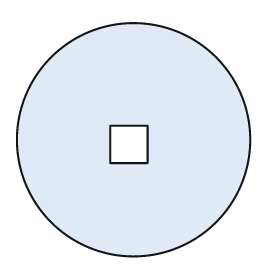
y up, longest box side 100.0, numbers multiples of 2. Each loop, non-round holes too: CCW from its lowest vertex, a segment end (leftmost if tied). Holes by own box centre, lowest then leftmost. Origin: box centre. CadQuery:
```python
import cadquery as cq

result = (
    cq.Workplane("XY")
    .moveTo(0.0, 0.0)
    .circle(50.0)
    .moveTo(-10.0, -10.0)
    .lineTo(6.0, -10.0)
    .lineTo(6.0, 6.0)
    .lineTo(-10.0, 6.0)
    .close()
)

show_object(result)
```